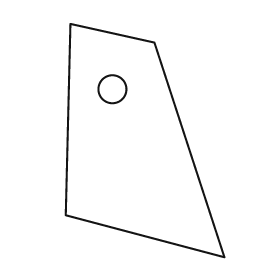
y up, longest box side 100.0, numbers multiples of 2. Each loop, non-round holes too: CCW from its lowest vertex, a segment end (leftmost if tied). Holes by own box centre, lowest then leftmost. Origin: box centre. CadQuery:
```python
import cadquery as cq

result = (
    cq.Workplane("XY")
    .moveTo(34.0, -50.0)
    .lineTo(4.0, 42.0)
    .lineTo(-32.0, 50.0)
    .lineTo(-34.0, -32.0)
    .close()
    .moveTo(-14.0, 22.0)
    .circle(6.0)
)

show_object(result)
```